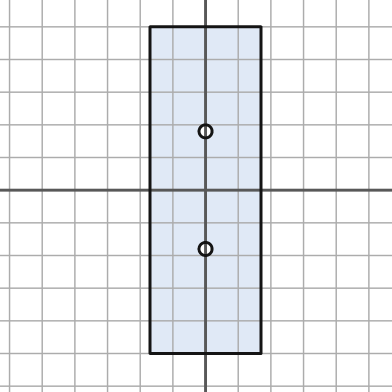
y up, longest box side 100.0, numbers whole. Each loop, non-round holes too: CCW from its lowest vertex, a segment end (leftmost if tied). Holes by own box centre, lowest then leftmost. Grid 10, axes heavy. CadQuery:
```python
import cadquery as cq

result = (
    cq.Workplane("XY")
    .moveTo(-17.0, -50.0)
    .lineTo(17.0, -50.0)
    .lineTo(17.0, 50.0)
    .lineTo(-17.0, 50.0)
    .close()
    .moveTo(0.0, -18.0)
    .circle(2.0)
    .moveTo(0.0, 18.0)
    .circle(2.0)
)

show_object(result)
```